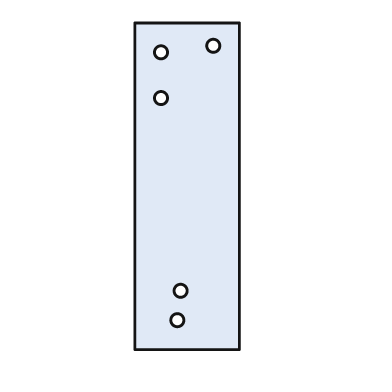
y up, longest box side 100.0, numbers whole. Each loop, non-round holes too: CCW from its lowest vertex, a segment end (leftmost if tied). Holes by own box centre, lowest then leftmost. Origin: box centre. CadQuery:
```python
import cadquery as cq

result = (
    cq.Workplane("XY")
    .moveTo(-16.0, -50.0)
    .lineTo(16.0, -50.0)
    .lineTo(16.0, 50.0)
    .lineTo(-16.0, 50.0)
    .close()
    .moveTo(-3.0, -41.0)
    .circle(2.0)
    .moveTo(-2.0, -32.0)
    .circle(2.0)
    .moveTo(-8.0, 27.0)
    .circle(2.0)
    .moveTo(-8.0, 41.0)
    .circle(2.0)
    .moveTo(8.0, 43.0)
    .circle(2.0)
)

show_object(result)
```